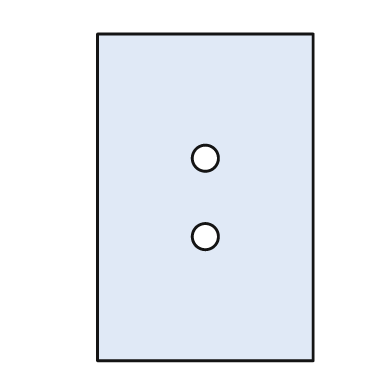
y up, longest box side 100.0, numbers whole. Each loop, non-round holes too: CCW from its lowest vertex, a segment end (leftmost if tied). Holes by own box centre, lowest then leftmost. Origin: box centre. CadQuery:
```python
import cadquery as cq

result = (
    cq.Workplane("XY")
    .moveTo(-33.0, -50.0)
    .lineTo(33.0, -50.0)
    .lineTo(33.0, 50.0)
    .lineTo(-33.0, 50.0)
    .close()
    .moveTo(0.0, -12.0)
    .circle(4.0)
    .moveTo(0.0, 12.0)
    .circle(4.0)
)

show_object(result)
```